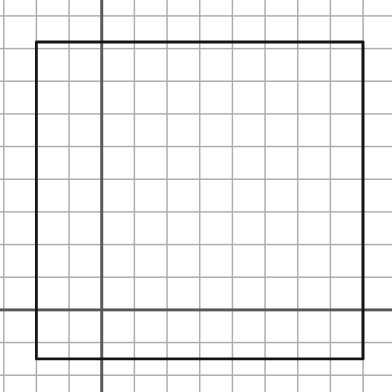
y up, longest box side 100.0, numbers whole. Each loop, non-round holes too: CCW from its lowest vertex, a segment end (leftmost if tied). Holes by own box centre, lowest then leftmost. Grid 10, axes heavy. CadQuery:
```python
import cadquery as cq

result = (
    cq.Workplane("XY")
    .moveTo(-20.0, -15.0)
    .lineTo(80.0, -15.0)
    .lineTo(80.0, 82.0)
    .lineTo(-20.0, 82.0)
    .close()
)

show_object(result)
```